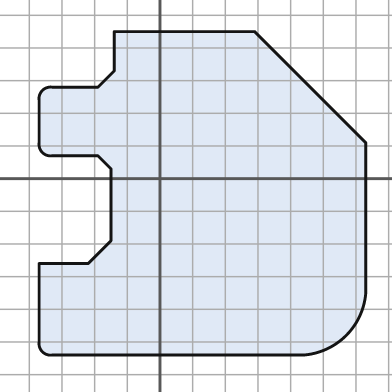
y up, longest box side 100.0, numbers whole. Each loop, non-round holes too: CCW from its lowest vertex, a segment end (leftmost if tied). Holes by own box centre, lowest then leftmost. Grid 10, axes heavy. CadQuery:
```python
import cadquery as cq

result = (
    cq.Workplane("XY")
    .moveTo(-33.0, -54.0)
    .lineTo(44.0, -54.0)
    .threePointArc((57.0, -48.0), (63.0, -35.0))
    .lineTo(63.0, 11.0)
    .lineTo(29.0, 45.0)
    .lineTo(-14.0, 45.0)
    .lineTo(-14.0, 33.0)
    .lineTo(-19.0, 28.0)
    .lineTo(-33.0, 28.0)
    .threePointArc((-36.0, 27.0), (-37.0, 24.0))
    .lineTo(-37.0, 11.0)
    .threePointArc((-36.0, 8.0), (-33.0, 7.0))
    .lineTo(-19.0, 7.0)
    .lineTo(-15.0, 3.0)
    .lineTo(-15.0, -19.0)
    .lineTo(-22.0, -26.0)
    .lineTo(-37.0, -26.0)
    .lineTo(-37.0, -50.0)
    .threePointArc((-36.0, -53.0), (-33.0, -54.0))
    .close()
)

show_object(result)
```